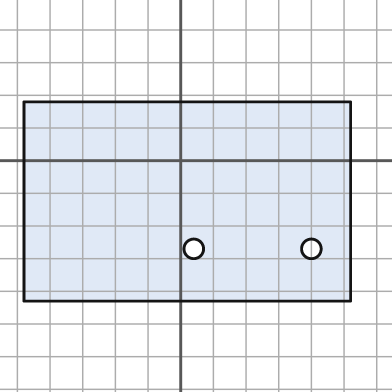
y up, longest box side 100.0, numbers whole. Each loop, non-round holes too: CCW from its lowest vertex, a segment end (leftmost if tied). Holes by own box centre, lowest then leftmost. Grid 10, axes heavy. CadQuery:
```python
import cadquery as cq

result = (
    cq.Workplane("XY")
    .moveTo(-48.0, -43.0)
    .lineTo(52.0, -43.0)
    .lineTo(52.0, 18.0)
    .lineTo(-48.0, 18.0)
    .close()
    .moveTo(4.0, -27.0)
    .circle(3.0)
    .moveTo(40.0, -27.0)
    .circle(3.0)
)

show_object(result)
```